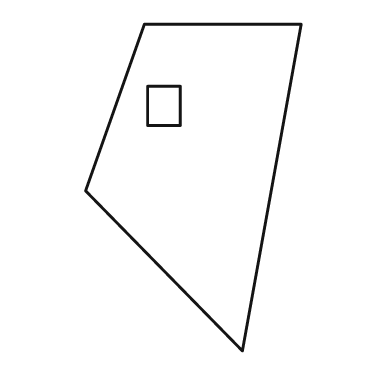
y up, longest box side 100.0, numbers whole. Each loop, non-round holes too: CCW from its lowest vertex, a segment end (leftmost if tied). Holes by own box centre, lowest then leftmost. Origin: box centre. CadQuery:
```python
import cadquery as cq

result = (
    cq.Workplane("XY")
    .moveTo(15.0, -50.0)
    .lineTo(33.0, 50.0)
    .lineTo(-15.0, 50.0)
    .lineTo(-33.0, -1.0)
    .close()
    .moveTo(-14.0, 19.0)
    .lineTo(-4.0, 19.0)
    .lineTo(-4.0, 31.0)
    .lineTo(-14.0, 31.0)
    .close()
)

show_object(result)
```